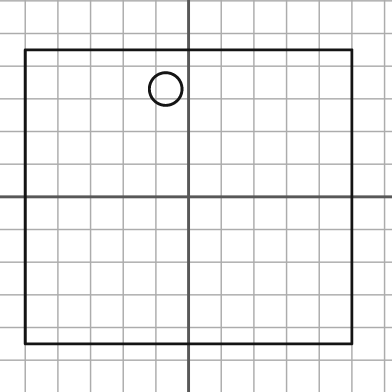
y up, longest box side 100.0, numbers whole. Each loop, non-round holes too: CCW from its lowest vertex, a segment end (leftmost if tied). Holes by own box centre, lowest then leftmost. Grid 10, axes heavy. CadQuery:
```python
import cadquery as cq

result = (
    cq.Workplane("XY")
    .moveTo(-50.0, -45.0)
    .lineTo(50.0, -45.0)
    .lineTo(50.0, 45.0)
    .lineTo(-50.0, 45.0)
    .close()
    .moveTo(-7.0, 33.0)
    .circle(5.0)
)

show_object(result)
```